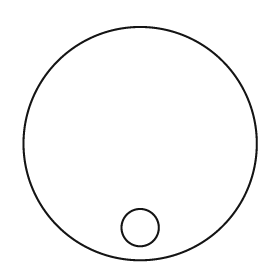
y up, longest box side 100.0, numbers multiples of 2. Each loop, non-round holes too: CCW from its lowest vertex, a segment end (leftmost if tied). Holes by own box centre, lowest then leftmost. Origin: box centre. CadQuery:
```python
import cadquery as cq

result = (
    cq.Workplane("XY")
    .moveTo(0.0, 0.0)
    .circle(50.0)
    .moveTo(0.0, -36.0)
    .circle(8.0)
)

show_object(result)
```